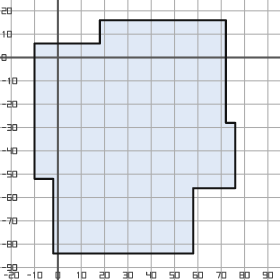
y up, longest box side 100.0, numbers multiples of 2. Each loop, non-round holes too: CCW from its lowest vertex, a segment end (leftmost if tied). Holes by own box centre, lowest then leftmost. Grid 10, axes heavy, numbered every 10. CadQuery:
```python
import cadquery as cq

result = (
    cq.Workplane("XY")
    .moveTo(-2.0, -84.0)
    .lineTo(58.0, -84.0)
    .lineTo(58.0, -56.0)
    .lineTo(76.0, -56.0)
    .lineTo(76.0, -28.0)
    .lineTo(72.0, -28.0)
    .lineTo(72.0, 16.0)
    .lineTo(18.0, 16.0)
    .lineTo(18.0, 6.0)
    .lineTo(-10.0, 6.0)
    .lineTo(-10.0, -52.0)
    .lineTo(-2.0, -52.0)
    .close()
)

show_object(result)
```